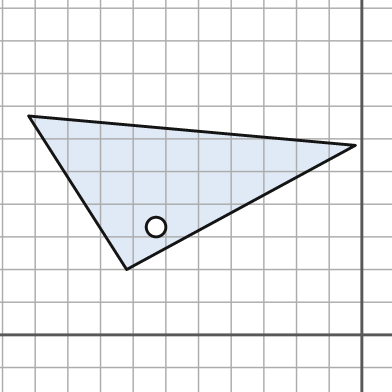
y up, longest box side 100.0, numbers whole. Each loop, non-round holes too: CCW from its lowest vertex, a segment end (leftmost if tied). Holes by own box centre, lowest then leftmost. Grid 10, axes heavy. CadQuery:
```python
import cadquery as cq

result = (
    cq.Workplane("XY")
    .moveTo(-72.0, 20.0)
    .lineTo(-2.0, 58.0)
    .lineTo(-102.0, 67.0)
    .close()
    .moveTo(-63.0, 33.0)
    .circle(3.0)
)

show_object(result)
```